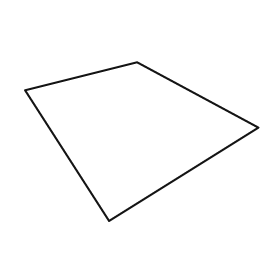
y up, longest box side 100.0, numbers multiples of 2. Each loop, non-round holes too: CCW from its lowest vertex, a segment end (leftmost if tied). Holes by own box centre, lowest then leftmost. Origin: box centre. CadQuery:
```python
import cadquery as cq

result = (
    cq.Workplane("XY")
    .moveTo(-14.0, -34.0)
    .lineTo(50.0, 6.0)
    .lineTo(-2.0, 34.0)
    .lineTo(-50.0, 22.0)
    .close()
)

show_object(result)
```